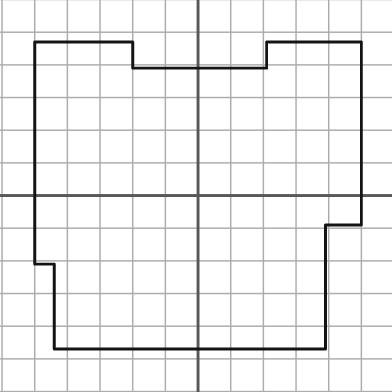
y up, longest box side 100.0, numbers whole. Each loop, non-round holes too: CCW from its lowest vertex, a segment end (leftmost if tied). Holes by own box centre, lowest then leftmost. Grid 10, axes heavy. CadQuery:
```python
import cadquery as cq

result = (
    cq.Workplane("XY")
    .moveTo(-44.0, -47.0)
    .lineTo(39.0, -47.0)
    .lineTo(39.0, -9.0)
    .lineTo(50.0, -9.0)
    .lineTo(50.0, 47.0)
    .lineTo(21.0, 47.0)
    .lineTo(21.0, 39.0)
    .lineTo(-20.0, 39.0)
    .lineTo(-20.0, 47.0)
    .lineTo(-50.0, 47.0)
    .lineTo(-50.0, -21.0)
    .lineTo(-44.0, -21.0)
    .close()
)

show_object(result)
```